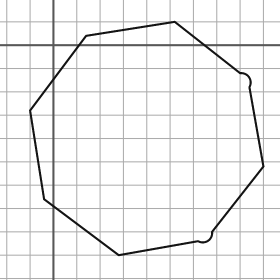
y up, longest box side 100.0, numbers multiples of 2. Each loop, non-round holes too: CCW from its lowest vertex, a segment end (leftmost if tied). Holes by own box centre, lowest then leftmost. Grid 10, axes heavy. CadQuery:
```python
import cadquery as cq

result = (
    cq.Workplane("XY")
    .moveTo(28.0, -90.0)
    .lineTo(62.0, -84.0)
    .threePointArc((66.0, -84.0), (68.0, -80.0))
    .lineTo(90.0, -52.0)
    .lineTo(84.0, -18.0)
    .threePointArc((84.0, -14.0), (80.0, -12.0))
    .lineTo(52.0, 10.0)
    .lineTo(14.0, 4.0)
    .lineTo(-10.0, -28.0)
    .lineTo(-4.0, -66.0)
    .close()
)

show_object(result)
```